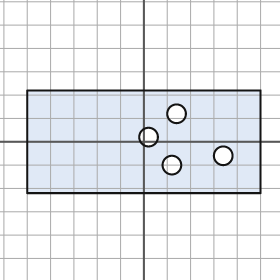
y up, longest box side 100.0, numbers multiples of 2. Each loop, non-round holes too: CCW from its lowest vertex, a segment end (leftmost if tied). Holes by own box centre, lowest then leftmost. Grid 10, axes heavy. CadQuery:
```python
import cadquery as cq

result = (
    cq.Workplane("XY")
    .moveTo(-50.0, -22.0)
    .lineTo(50.0, -22.0)
    .lineTo(50.0, 22.0)
    .lineTo(-50.0, 22.0)
    .close()
    .moveTo(12.0, -10.0)
    .circle(4.0)
    .moveTo(34.0, -6.0)
    .circle(4.0)
    .moveTo(2.0, 2.0)
    .circle(4.0)
    .moveTo(14.0, 12.0)
    .circle(4.0)
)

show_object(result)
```